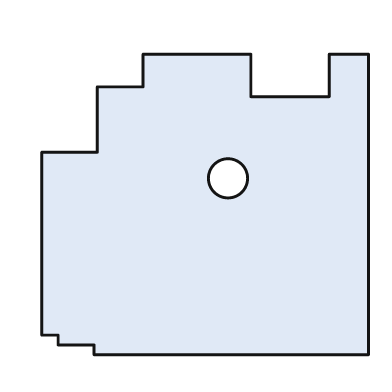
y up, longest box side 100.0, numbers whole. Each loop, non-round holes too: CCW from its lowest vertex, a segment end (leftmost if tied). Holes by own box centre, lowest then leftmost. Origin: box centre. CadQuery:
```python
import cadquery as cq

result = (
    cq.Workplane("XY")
    .moveTo(-34.0, -46.0)
    .lineTo(50.0, -46.0)
    .lineTo(50.0, 46.0)
    .lineTo(38.0, 46.0)
    .lineTo(38.0, 33.0)
    .lineTo(14.0, 33.0)
    .lineTo(14.0, 46.0)
    .lineTo(-19.0, 46.0)
    .lineTo(-19.0, 36.0)
    .lineTo(-33.0, 36.0)
    .lineTo(-33.0, 16.0)
    .lineTo(-50.0, 16.0)
    .lineTo(-50.0, -40.0)
    .lineTo(-45.0, -40.0)
    .lineTo(-45.0, -43.0)
    .lineTo(-34.0, -43.0)
    .close()
    .moveTo(7.0, 8.0)
    .circle(6.0)
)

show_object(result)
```